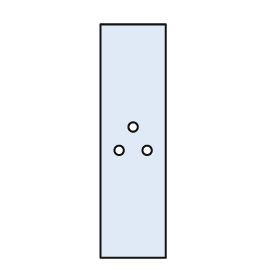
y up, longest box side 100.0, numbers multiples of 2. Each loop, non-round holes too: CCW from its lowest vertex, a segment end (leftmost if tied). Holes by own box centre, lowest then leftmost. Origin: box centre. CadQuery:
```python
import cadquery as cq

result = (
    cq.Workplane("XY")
    .moveTo(-14.0, -50.0)
    .lineTo(14.0, -50.0)
    .lineTo(14.0, 50.0)
    .lineTo(-14.0, 50.0)
    .close()
    .moveTo(-6.0, -4.0)
    .circle(2.0)
    .moveTo(6.0, -4.0)
    .circle(2.0)
    .moveTo(0.0, 6.0)
    .circle(2.0)
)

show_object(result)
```